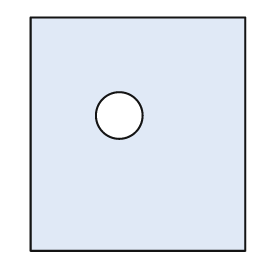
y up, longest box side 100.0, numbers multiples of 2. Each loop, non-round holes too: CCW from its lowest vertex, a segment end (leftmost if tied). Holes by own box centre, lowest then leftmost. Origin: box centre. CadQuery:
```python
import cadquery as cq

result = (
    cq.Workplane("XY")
    .moveTo(-46.0, -50.0)
    .lineTo(46.0, -50.0)
    .lineTo(46.0, 50.0)
    .lineTo(-46.0, 50.0)
    .close()
    .moveTo(-8.0, 8.0)
    .circle(10.0)
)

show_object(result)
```